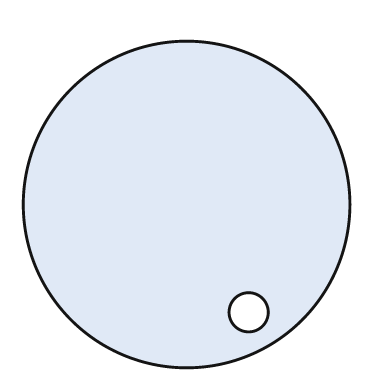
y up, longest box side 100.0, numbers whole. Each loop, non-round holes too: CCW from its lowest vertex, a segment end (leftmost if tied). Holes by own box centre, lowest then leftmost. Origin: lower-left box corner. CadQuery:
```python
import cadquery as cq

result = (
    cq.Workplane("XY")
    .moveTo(50.0, 50.0)
    .circle(50.0)
    .moveTo(69.0, 17.0)
    .circle(6.0)
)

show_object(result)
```